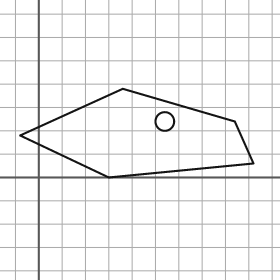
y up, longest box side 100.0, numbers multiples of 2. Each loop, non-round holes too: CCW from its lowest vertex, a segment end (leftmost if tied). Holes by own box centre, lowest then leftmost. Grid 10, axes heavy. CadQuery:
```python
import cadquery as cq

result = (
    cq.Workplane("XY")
    .moveTo(30.0, 0.0)
    .lineTo(92.0, 6.0)
    .lineTo(84.0, 24.0)
    .lineTo(36.0, 38.0)
    .lineTo(-8.0, 18.0)
    .close()
    .moveTo(54.0, 24.0)
    .circle(4.0)
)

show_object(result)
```